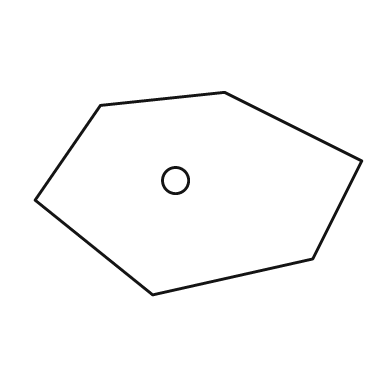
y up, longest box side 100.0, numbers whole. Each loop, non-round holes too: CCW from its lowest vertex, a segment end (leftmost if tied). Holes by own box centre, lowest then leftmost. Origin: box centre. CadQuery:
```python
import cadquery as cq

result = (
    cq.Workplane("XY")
    .moveTo(-14.0, -31.0)
    .lineTo(35.0, -20.0)
    .lineTo(50.0, 10.0)
    .lineTo(8.0, 31.0)
    .lineTo(-30.0, 27.0)
    .lineTo(-50.0, -2.0)
    .close()
    .moveTo(-7.0, 4.0)
    .circle(4.0)
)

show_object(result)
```